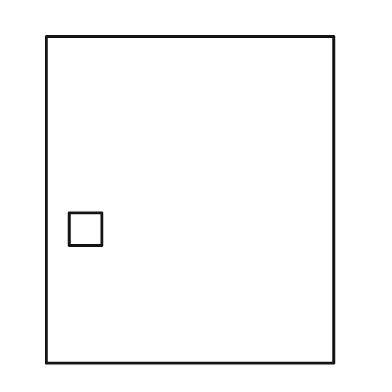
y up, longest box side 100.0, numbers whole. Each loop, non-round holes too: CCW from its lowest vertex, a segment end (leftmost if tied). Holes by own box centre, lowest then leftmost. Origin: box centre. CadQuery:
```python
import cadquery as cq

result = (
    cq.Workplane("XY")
    .moveTo(-44.0, -50.0)
    .lineTo(44.0, -50.0)
    .lineTo(44.0, 50.0)
    .lineTo(-44.0, 50.0)
    .close()
    .moveTo(-37.0, -14.0)
    .lineTo(-27.0, -14.0)
    .lineTo(-27.0, -4.0)
    .lineTo(-37.0, -4.0)
    .close()
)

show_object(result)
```